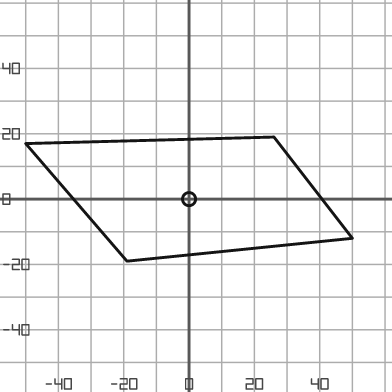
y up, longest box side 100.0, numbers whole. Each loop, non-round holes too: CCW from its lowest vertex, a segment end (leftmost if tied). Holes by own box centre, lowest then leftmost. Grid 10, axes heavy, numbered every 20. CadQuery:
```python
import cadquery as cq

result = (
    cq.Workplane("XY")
    .moveTo(-19.0, -19.0)
    .lineTo(50.0, -12.0)
    .lineTo(26.0, 19.0)
    .lineTo(-50.0, 17.0)
    .close()
    .moveTo(0.0, 0.0)
    .circle(2.0)
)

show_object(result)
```